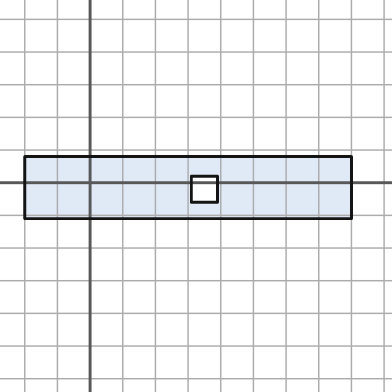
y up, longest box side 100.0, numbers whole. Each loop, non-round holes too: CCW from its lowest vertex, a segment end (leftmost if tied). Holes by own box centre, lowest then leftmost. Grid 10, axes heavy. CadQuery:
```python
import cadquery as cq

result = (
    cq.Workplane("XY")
    .moveTo(-20.0, -11.0)
    .lineTo(80.0, -11.0)
    .lineTo(80.0, 8.0)
    .lineTo(-20.0, 8.0)
    .close()
    .moveTo(31.0, -6.0)
    .lineTo(39.0, -6.0)
    .lineTo(39.0, 2.0)
    .lineTo(31.0, 2.0)
    .close()
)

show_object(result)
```